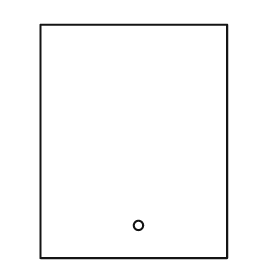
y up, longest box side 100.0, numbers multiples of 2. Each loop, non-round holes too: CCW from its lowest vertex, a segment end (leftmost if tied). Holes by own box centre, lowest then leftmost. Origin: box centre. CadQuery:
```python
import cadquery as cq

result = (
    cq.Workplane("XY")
    .moveTo(-40.0, -50.0)
    .lineTo(40.0, -50.0)
    .lineTo(40.0, 50.0)
    .lineTo(-40.0, 50.0)
    .close()
    .moveTo(2.0, -36.0)
    .circle(2.0)
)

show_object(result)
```